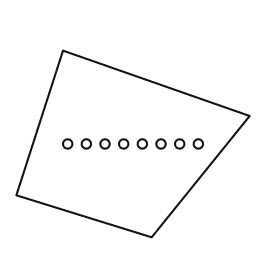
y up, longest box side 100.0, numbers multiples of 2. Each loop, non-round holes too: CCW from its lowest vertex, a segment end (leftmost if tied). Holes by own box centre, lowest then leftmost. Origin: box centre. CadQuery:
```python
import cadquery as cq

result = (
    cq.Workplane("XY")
    .moveTo(8.0, -40.0)
    .lineTo(50.0, 12.0)
    .lineTo(-30.0, 40.0)
    .lineTo(-50.0, -22.0)
    .close()
    .moveTo(-28.0, 0.0)
    .circle(2.0)
    .moveTo(-20.0, 0.0)
    .circle(2.0)
    .moveTo(-12.0, 0.0)
    .circle(2.0)
    .moveTo(-4.0, 0.0)
    .circle(2.0)
    .moveTo(4.0, 0.0)
    .circle(2.0)
    .moveTo(12.0, 0.0)
    .circle(2.0)
    .moveTo(20.0, 0.0)
    .circle(2.0)
    .moveTo(28.0, 0.0)
    .circle(2.0)
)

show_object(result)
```